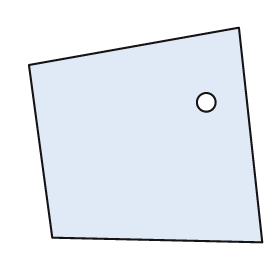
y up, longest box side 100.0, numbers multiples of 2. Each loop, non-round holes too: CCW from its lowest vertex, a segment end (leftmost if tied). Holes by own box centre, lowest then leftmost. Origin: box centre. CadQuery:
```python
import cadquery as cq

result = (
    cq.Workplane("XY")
    .moveTo(50.0, -46.0)
    .lineTo(40.0, 46.0)
    .lineTo(-50.0, 30.0)
    .lineTo(-40.0, -44.0)
    .close()
    .moveTo(26.0, 14.0)
    .circle(4.0)
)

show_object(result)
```